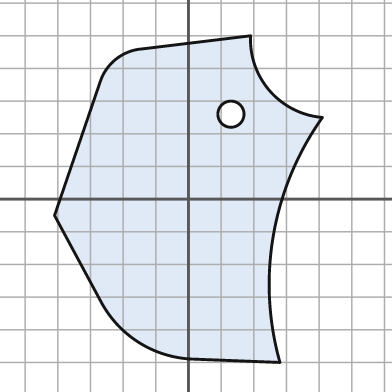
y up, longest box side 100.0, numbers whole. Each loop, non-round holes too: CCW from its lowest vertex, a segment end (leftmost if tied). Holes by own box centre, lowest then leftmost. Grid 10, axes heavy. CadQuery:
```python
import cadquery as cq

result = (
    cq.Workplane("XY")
    .moveTo(28.0, -50.0)
    .threePointArc((26.0, -11.0), (41.0, 25.0))
    .threePointArc((25.0, 33.0), (19.0, 50.0))
    .lineTo(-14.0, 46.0)
    .threePointArc((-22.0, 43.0), (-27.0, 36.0))
    .lineTo(-41.0, -5.0)
    .lineTo(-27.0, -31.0)
    .threePointArc((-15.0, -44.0), (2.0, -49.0))
    .close()
    .moveTo(13.0, 26.0)
    .circle(4.0)
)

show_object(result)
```